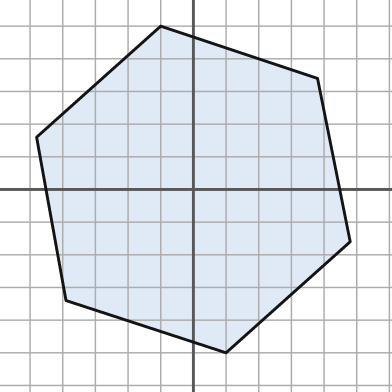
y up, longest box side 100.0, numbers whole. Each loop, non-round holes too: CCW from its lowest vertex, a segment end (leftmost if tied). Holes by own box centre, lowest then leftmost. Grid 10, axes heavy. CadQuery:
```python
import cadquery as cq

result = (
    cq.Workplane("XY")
    .moveTo(10.0, -50.0)
    .lineTo(48.0, -16.0)
    .lineTo(38.0, 34.0)
    .lineTo(-10.0, 50.0)
    .lineTo(-48.0, 16.0)
    .lineTo(-39.0, -34.0)
    .close()
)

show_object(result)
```